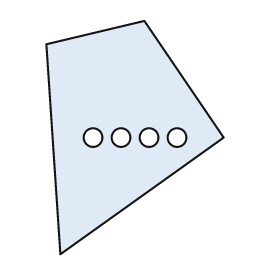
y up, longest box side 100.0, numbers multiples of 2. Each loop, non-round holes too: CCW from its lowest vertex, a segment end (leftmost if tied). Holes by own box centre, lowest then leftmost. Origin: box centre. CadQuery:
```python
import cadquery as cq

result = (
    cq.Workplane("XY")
    .moveTo(-32.0, -50.0)
    .lineTo(38.0, 0.0)
    .lineTo(4.0, 50.0)
    .lineTo(-38.0, 40.0)
    .close()
    .moveTo(-18.0, 0.0)
    .circle(4.0)
    .moveTo(-6.0, 0.0)
    .circle(4.0)
    .moveTo(6.0, 0.0)
    .circle(4.0)
    .moveTo(18.0, 0.0)
    .circle(4.0)
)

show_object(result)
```